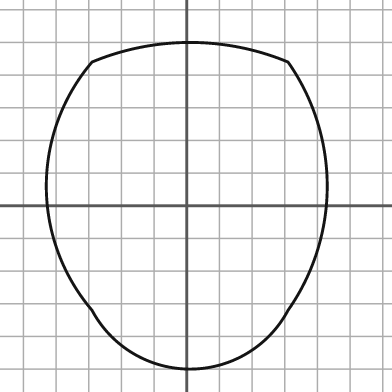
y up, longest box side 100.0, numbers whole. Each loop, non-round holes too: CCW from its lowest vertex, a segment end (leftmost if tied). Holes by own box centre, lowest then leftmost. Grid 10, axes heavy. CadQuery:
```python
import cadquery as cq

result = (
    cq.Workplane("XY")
    .moveTo(-29.0, -32.0)
    .threePointArc((1.0, -50.0), (31.0, -32.0))
    .threePointArc((43.0, 6.0), (31.0, 44.0))
    .threePointArc((1.0, 50.0), (-29.0, 44.0))
    .threePointArc((-43.0, 6.0), (-29.0, -32.0))
    .close()
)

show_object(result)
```